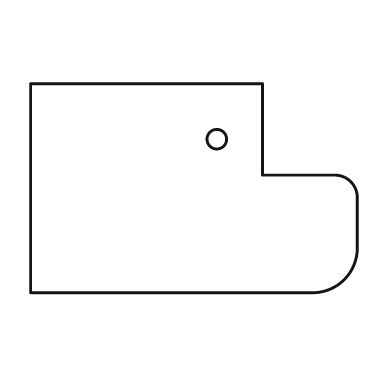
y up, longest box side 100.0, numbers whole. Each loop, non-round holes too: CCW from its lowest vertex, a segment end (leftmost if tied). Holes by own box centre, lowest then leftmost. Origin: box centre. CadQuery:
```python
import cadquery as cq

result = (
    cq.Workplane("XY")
    .moveTo(-50.0, -32.0)
    .lineTo(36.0, -32.0)
    .threePointArc((46.0, -28.0), (50.0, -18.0))
    .lineTo(50.0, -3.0)
    .threePointArc((48.0, 2.0), (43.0, 4.0))
    .lineTo(21.0, 4.0)
    .lineTo(21.0, 32.0)
    .lineTo(-50.0, 32.0)
    .close()
    .moveTo(7.0, 15.0)
    .circle(3.0)
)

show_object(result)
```